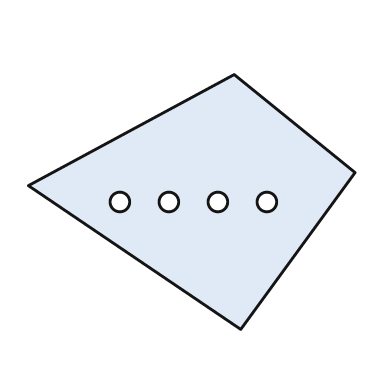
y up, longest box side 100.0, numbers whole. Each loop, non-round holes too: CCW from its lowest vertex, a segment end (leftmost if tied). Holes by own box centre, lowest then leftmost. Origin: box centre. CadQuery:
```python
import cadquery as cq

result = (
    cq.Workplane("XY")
    .moveTo(15.0, -39.0)
    .lineTo(50.0, 9.0)
    .lineTo(13.0, 39.0)
    .lineTo(-50.0, 5.0)
    .close()
    .moveTo(-22.0, 0.0)
    .circle(3.0)
    .moveTo(-7.0, 0.0)
    .circle(3.0)
    .moveTo(8.0, 0.0)
    .circle(3.0)
    .moveTo(23.0, 0.0)
    .circle(3.0)
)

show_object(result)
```